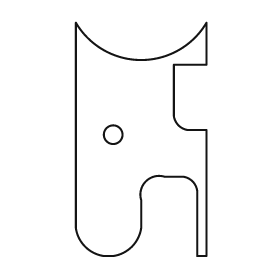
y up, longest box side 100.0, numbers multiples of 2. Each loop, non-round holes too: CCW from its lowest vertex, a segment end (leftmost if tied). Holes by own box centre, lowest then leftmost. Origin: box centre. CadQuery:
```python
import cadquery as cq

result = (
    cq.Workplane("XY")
    .moveTo(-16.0, -50.0)
    .lineTo(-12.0, -50.0)
    .threePointArc((-4.0, -46.0), (0.0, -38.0))
    .lineTo(0.0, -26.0)
    .threePointArc((2.0, -18.0), (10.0, -16.0))
    .lineTo(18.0, -16.0)
    .threePointArc((22.0, -18.0), (24.0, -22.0))
    .lineTo(24.0, -50.0)
    .lineTo(28.0, -50.0)
    .lineTo(28.0, 4.0)
    .lineTo(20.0, 4.0)
    .threePointArc((16.0, 6.0), (14.0, 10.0))
    .lineTo(14.0, 32.0)
    .lineTo(28.0, 32.0)
    .lineTo(28.0, 50.0)
    .threePointArc((0.0, 34.0), (-28.0, 50.0))
    .lineTo(-28.0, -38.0)
    .threePointArc((-24.0, -46.0), (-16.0, -50.0))
    .close()
    .moveTo(-12.0, 2.0)
    .circle(4.0)
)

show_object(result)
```